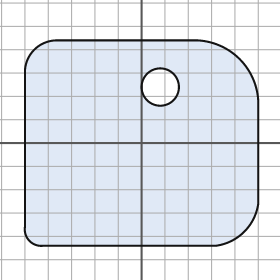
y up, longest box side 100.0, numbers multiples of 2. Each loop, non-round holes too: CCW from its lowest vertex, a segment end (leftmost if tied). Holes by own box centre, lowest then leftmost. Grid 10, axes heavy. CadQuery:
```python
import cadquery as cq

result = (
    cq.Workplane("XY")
    .moveTo(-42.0, -44.0)
    .lineTo(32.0, -44.0)
    .threePointArc((44.0, -38.0), (50.0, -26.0))
    .lineTo(50.0, 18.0)
    .threePointArc((42.0, 36.0), (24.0, 44.0))
    .lineTo(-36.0, 44.0)
    .threePointArc((-46.0, 40.0), (-50.0, 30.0))
    .lineTo(-50.0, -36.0)
    .threePointArc((-48.0, -42.0), (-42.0, -44.0))
    .close()
    .moveTo(8.0, 24.0)
    .circle(8.0)
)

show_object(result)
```